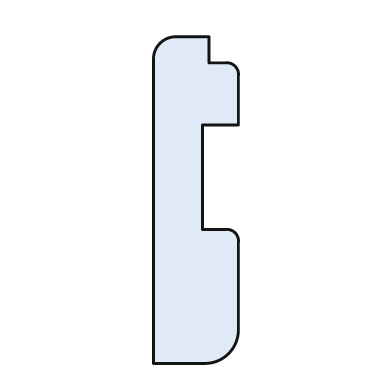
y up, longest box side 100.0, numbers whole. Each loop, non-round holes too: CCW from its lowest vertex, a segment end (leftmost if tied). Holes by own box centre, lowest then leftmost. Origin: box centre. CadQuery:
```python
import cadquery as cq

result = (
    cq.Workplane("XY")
    .moveTo(-13.0, -50.0)
    .lineTo(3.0, -50.0)
    .threePointArc((10.0, -47.0), (13.0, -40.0))
    .lineTo(13.0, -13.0)
    .threePointArc((12.0, -10.0), (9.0, -9.0))
    .lineTo(2.0, -9.0)
    .lineTo(2.0, 23.0)
    .lineTo(13.0, 23.0)
    .lineTo(13.0, 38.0)
    .threePointArc((12.0, 41.0), (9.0, 42.0))
    .lineTo(4.0, 42.0)
    .lineTo(4.0, 50.0)
    .lineTo(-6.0, 50.0)
    .threePointArc((-11.0, 48.0), (-13.0, 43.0))
    .close()
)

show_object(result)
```